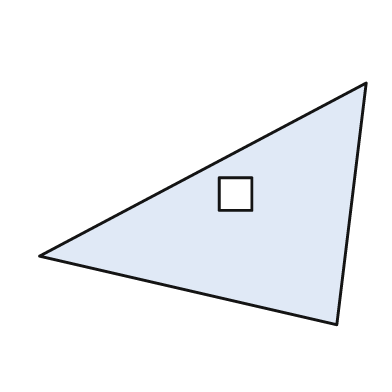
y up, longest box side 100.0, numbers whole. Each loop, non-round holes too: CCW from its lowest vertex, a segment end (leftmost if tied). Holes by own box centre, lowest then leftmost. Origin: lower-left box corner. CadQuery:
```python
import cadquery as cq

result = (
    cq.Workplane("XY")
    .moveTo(91.0, 0.0)
    .lineTo(100.0, 74.0)
    .lineTo(0.0, 21.0)
    .close()
    .moveTo(55.0, 35.0)
    .lineTo(65.0, 35.0)
    .lineTo(65.0, 45.0)
    .lineTo(55.0, 45.0)
    .close()
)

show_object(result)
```